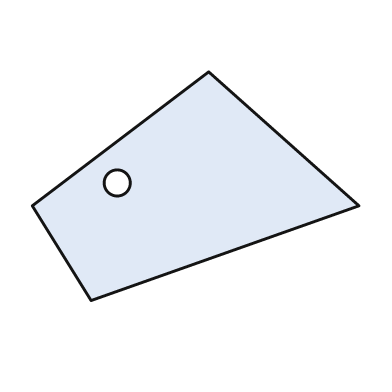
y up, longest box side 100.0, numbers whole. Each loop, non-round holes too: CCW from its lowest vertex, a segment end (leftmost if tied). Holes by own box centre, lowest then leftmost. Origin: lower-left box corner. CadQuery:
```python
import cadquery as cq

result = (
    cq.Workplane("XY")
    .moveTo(18.0, 0.0)
    .lineTo(100.0, 29.0)
    .lineTo(54.0, 70.0)
    .lineTo(0.0, 29.0)
    .close()
    .moveTo(26.0, 36.0)
    .circle(4.0)
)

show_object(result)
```